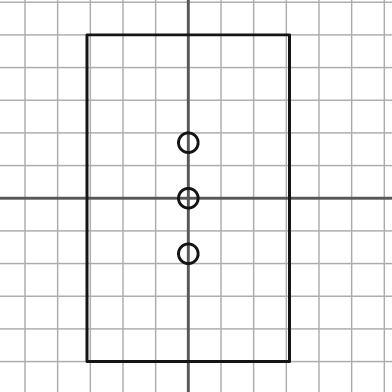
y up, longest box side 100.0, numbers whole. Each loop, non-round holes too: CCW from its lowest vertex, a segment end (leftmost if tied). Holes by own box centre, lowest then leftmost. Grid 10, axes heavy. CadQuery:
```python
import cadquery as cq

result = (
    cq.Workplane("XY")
    .moveTo(-31.0, -50.0)
    .lineTo(31.0, -50.0)
    .lineTo(31.0, 50.0)
    .lineTo(-31.0, 50.0)
    .close()
    .moveTo(0.0, -17.0)
    .circle(3.0)
    .moveTo(0.0, 0.0)
    .circle(3.0)
    .moveTo(0.0, 17.0)
    .circle(3.0)
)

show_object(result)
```